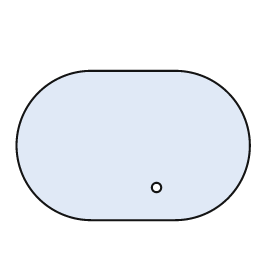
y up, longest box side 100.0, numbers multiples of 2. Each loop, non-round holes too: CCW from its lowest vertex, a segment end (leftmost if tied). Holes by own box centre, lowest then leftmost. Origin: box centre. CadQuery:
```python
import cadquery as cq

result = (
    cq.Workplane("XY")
    .moveTo(-18.0, -32.0)
    .lineTo(18.0, -32.0)
    .threePointArc((50.0, 0.0), (18.0, 32.0))
    .lineTo(-18.0, 32.0)
    .threePointArc((-50.0, 0.0), (-18.0, -32.0))
    .close()
    .moveTo(10.0, -18.0)
    .circle(2.0)
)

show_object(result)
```